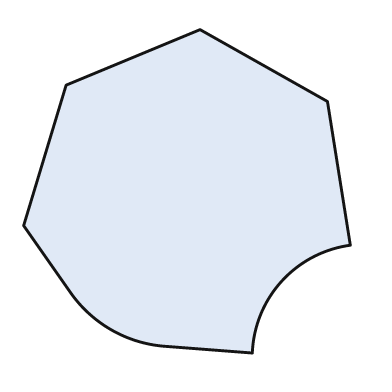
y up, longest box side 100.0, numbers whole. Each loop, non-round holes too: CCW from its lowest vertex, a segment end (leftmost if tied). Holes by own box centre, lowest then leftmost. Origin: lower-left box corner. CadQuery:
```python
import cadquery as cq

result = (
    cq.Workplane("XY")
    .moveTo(70.0, 0.0)
    .threePointArc((79.0, 22.0), (100.0, 33.0))
    .lineTo(93.0, 77.0)
    .lineTo(54.0, 99.0)
    .lineTo(13.0, 82.0)
    .lineTo(0.0, 39.0)
    .lineTo(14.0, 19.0)
    .threePointArc((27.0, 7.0), (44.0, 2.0))
    .close()
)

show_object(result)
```